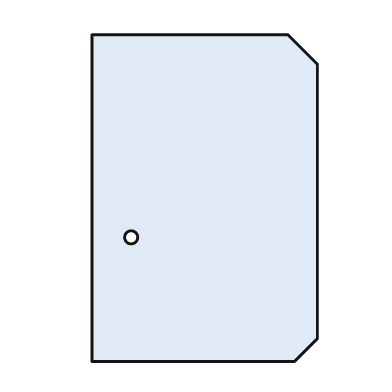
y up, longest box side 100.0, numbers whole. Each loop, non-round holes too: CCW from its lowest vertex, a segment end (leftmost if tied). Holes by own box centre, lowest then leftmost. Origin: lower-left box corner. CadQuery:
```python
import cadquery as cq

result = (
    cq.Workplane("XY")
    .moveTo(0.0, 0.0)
    .lineTo(62.0, 0.0)
    .lineTo(69.0, 7.0)
    .lineTo(69.0, 91.0)
    .lineTo(60.0, 100.0)
    .lineTo(0.0, 100.0)
    .close()
    .moveTo(12.0, 38.0)
    .circle(2.0)
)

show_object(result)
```